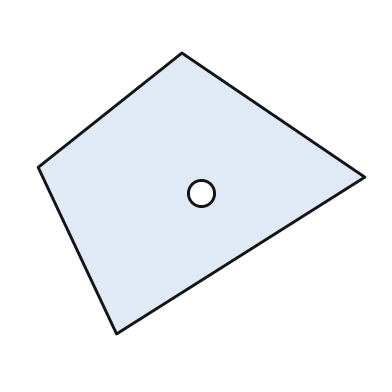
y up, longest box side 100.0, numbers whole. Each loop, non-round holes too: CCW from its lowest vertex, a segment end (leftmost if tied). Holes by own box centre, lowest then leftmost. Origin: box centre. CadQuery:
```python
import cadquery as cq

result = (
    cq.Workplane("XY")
    .moveTo(-26.0, -43.0)
    .lineTo(50.0, 5.0)
    .lineTo(-6.0, 43.0)
    .lineTo(-50.0, 8.0)
    .close()
    .moveTo(0.0, 0.0)
    .circle(4.0)
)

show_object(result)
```